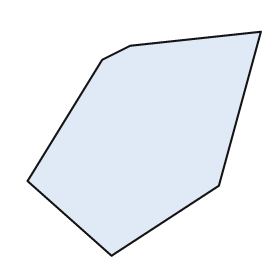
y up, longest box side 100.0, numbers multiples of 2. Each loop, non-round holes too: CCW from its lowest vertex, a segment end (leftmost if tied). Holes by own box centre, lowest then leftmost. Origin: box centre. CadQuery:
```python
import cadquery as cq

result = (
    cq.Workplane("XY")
    .moveTo(-14.0, -48.0)
    .lineTo(32.0, -18.0)
    .lineTo(50.0, 48.0)
    .lineTo(-6.0, 42.0)
    .lineTo(-18.0, 36.0)
    .lineTo(-50.0, -16.0)
    .close()
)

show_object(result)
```